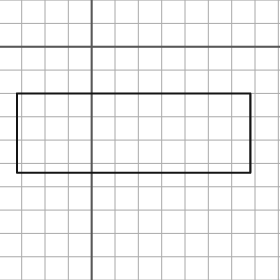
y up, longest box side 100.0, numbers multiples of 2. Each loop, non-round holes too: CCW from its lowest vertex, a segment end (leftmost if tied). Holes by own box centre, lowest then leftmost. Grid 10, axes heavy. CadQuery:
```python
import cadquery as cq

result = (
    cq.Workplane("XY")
    .moveTo(-32.0, -54.0)
    .lineTo(68.0, -54.0)
    .lineTo(68.0, -20.0)
    .lineTo(-32.0, -20.0)
    .close()
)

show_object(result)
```